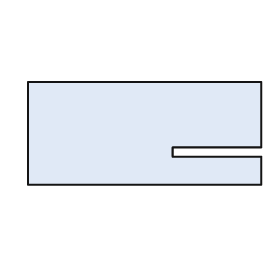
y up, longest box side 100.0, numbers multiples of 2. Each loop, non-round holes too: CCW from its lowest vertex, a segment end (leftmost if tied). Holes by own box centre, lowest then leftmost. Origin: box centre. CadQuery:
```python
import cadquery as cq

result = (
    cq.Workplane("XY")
    .moveTo(-50.0, -22.0)
    .lineTo(50.0, -22.0)
    .lineTo(50.0, -10.0)
    .lineTo(12.0, -10.0)
    .lineTo(12.0, -6.0)
    .lineTo(50.0, -6.0)
    .lineTo(50.0, 22.0)
    .lineTo(-50.0, 22.0)
    .close()
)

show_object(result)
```